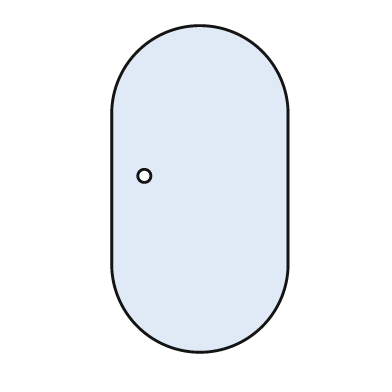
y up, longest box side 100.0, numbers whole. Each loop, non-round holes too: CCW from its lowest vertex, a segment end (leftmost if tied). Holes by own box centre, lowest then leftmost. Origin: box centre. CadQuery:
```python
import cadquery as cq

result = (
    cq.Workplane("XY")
    .moveTo(-27.0, -23.0)
    .threePointArc((0.0, -50.0), (27.0, -23.0))
    .lineTo(27.0, 23.0)
    .threePointArc((0.0, 50.0), (-27.0, 23.0))
    .close()
    .moveTo(-17.0, 4.0)
    .circle(2.0)
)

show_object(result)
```